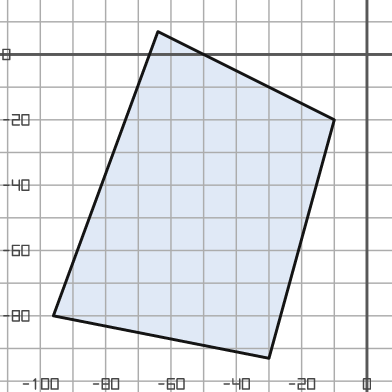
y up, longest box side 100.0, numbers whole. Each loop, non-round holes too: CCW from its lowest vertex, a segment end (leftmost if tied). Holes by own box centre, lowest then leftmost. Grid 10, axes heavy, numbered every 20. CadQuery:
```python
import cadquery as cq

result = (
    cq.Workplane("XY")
    .moveTo(-30.0, -93.0)
    .lineTo(-10.0, -20.0)
    .lineTo(-64.0, 7.0)
    .lineTo(-96.0, -80.0)
    .close()
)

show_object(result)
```